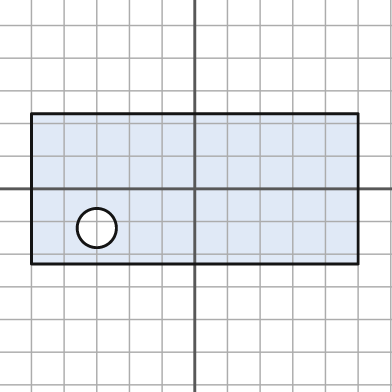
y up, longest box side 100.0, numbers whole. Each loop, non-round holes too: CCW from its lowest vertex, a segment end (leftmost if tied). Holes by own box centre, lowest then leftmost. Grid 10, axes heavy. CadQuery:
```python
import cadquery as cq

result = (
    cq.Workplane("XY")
    .moveTo(-50.0, -23.0)
    .lineTo(50.0, -23.0)
    .lineTo(50.0, 23.0)
    .lineTo(-50.0, 23.0)
    .close()
    .moveTo(-30.0, -12.0)
    .circle(6.0)
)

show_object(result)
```